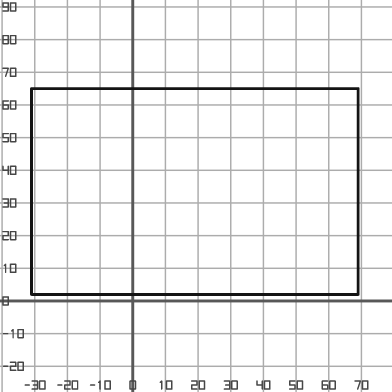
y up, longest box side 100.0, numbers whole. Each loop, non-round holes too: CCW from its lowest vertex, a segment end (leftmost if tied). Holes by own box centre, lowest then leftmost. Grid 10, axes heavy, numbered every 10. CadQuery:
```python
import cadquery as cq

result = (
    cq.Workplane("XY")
    .moveTo(-31.0, 2.0)
    .lineTo(69.0, 2.0)
    .lineTo(69.0, 65.0)
    .lineTo(-31.0, 65.0)
    .close()
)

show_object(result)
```